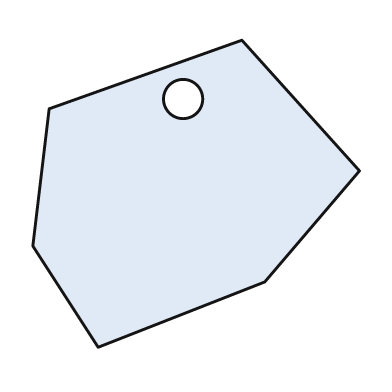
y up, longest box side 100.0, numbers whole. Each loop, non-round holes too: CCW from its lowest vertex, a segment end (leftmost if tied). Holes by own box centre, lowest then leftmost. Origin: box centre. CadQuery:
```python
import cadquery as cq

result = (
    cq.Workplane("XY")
    .moveTo(-30.0, -47.0)
    .lineTo(21.0, -27.0)
    .lineTo(50.0, 7.0)
    .lineTo(14.0, 47.0)
    .lineTo(-45.0, 26.0)
    .lineTo(-50.0, -16.0)
    .close()
    .moveTo(-4.0, 29.0)
    .circle(6.0)
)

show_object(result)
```